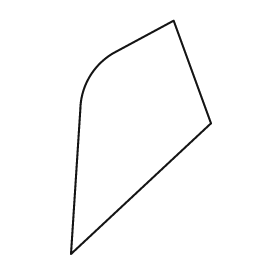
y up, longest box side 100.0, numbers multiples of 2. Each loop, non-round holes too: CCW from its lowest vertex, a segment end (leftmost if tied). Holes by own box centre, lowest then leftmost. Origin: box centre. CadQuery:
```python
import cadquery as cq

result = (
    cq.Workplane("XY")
    .moveTo(-30.0, -50.0)
    .lineTo(30.0, 6.0)
    .lineTo(14.0, 50.0)
    .lineTo(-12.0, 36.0)
    .threePointArc((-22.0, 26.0), (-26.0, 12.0))
    .close()
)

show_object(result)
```